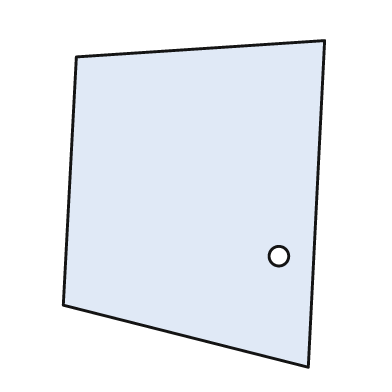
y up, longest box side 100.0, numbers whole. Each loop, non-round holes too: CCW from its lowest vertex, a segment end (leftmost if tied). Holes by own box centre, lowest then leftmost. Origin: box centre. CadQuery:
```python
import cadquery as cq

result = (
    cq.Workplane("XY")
    .moveTo(35.0, -50.0)
    .lineTo(40.0, 50.0)
    .lineTo(-36.0, 45.0)
    .lineTo(-40.0, -31.0)
    .close()
    .moveTo(26.0, -16.0)
    .circle(3.0)
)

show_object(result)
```